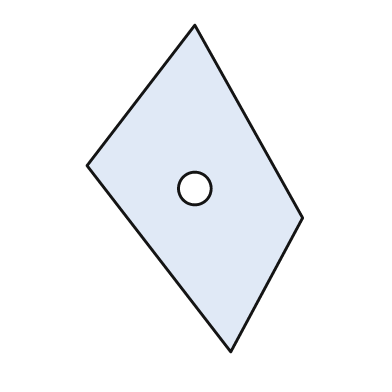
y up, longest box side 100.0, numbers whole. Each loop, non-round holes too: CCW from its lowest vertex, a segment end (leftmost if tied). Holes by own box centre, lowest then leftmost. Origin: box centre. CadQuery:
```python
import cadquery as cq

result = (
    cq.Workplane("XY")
    .moveTo(11.0, -50.0)
    .lineTo(33.0, -9.0)
    .lineTo(0.0, 50.0)
    .lineTo(-33.0, 7.0)
    .close()
    .moveTo(0.0, 0.0)
    .circle(5.0)
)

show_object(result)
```